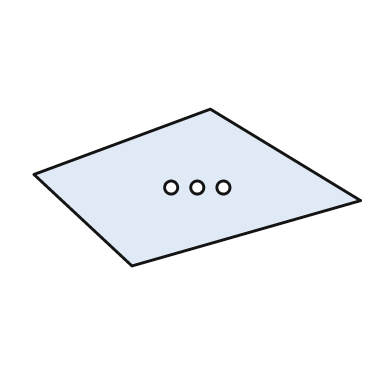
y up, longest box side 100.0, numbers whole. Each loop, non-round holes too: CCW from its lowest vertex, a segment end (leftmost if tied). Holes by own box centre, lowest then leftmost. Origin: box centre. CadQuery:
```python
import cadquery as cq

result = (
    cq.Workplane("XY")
    .moveTo(-20.0, -24.0)
    .lineTo(50.0, -4.0)
    .lineTo(4.0, 24.0)
    .lineTo(-50.0, 4.0)
    .close()
    .moveTo(-8.0, 0.0)
    .circle(2.0)
    .moveTo(0.0, 0.0)
    .circle(2.0)
    .moveTo(8.0, 0.0)
    .circle(2.0)
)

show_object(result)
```